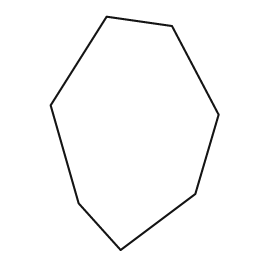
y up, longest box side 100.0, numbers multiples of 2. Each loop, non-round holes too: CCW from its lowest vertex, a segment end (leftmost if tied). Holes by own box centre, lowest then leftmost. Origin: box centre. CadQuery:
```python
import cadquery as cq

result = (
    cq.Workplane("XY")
    .moveTo(-6.0, -50.0)
    .lineTo(26.0, -26.0)
    .lineTo(36.0, 8.0)
    .lineTo(16.0, 46.0)
    .lineTo(-12.0, 50.0)
    .lineTo(-36.0, 12.0)
    .lineTo(-24.0, -30.0)
    .close()
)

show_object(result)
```